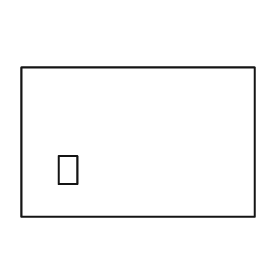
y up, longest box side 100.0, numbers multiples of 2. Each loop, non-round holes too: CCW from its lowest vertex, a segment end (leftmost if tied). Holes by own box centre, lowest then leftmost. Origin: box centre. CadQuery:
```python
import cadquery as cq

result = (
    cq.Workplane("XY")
    .moveTo(-50.0, -32.0)
    .lineTo(50.0, -32.0)
    .lineTo(50.0, 32.0)
    .lineTo(-50.0, 32.0)
    .close()
    .moveTo(-34.0, -18.0)
    .lineTo(-26.0, -18.0)
    .lineTo(-26.0, -6.0)
    .lineTo(-34.0, -6.0)
    .close()
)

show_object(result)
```